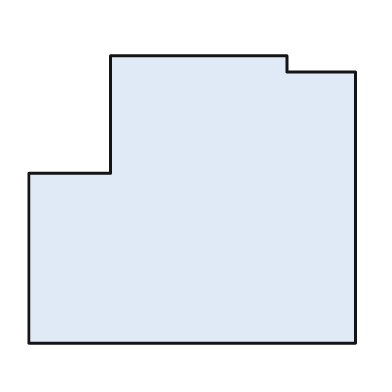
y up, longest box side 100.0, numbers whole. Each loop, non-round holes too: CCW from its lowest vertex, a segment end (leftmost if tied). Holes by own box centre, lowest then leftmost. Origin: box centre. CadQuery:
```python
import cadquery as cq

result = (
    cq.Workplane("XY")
    .moveTo(-50.0, -44.0)
    .lineTo(50.0, -44.0)
    .lineTo(50.0, 39.0)
    .lineTo(29.0, 39.0)
    .lineTo(29.0, 44.0)
    .lineTo(-25.0, 44.0)
    .lineTo(-25.0, 8.0)
    .lineTo(-50.0, 8.0)
    .close()
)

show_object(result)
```